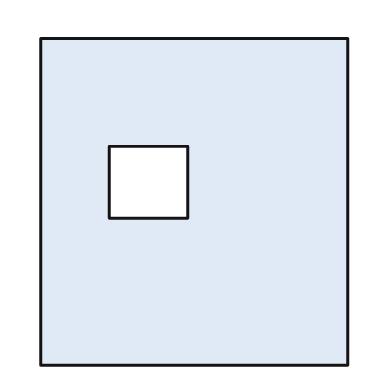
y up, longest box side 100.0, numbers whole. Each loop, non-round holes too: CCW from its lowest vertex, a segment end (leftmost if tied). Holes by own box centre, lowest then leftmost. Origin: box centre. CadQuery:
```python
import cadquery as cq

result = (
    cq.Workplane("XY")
    .moveTo(-47.0, -50.0)
    .lineTo(47.0, -50.0)
    .lineTo(47.0, 50.0)
    .lineTo(-47.0, 50.0)
    .close()
    .moveTo(-26.0, -5.0)
    .lineTo(-2.0, -5.0)
    .lineTo(-2.0, 17.0)
    .lineTo(-26.0, 17.0)
    .close()
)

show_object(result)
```